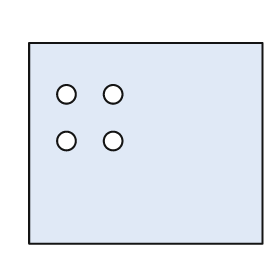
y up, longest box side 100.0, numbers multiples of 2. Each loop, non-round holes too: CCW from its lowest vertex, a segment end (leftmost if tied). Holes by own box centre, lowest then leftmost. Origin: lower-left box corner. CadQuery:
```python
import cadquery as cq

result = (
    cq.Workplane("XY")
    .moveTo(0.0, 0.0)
    .lineTo(100.0, 0.0)
    .lineTo(100.0, 86.0)
    .lineTo(0.0, 86.0)
    .close()
    .moveTo(16.0, 44.0)
    .circle(4.0)
    .moveTo(36.0, 44.0)
    .circle(4.0)
    .moveTo(16.0, 64.0)
    .circle(4.0)
    .moveTo(36.0, 64.0)
    .circle(4.0)
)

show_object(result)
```